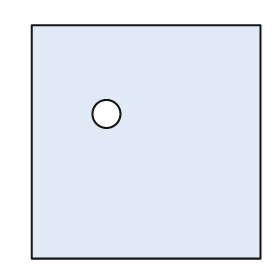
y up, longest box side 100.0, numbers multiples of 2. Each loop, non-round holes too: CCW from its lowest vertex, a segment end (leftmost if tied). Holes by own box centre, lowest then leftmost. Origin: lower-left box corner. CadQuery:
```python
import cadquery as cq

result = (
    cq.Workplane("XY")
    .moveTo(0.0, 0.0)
    .lineTo(98.0, 0.0)
    .lineTo(98.0, 100.0)
    .lineTo(0.0, 100.0)
    .close()
    .moveTo(32.0, 62.0)
    .circle(6.0)
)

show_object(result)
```